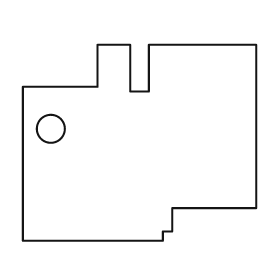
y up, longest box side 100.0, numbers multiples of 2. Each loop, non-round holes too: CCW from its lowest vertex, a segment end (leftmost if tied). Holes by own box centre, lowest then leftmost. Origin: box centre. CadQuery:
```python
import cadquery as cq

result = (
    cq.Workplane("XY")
    .moveTo(-50.0, -42.0)
    .lineTo(10.0, -42.0)
    .lineTo(10.0, -38.0)
    .lineTo(14.0, -38.0)
    .lineTo(14.0, -28.0)
    .lineTo(50.0, -28.0)
    .lineTo(50.0, 42.0)
    .lineTo(4.0, 42.0)
    .lineTo(4.0, 22.0)
    .lineTo(-4.0, 22.0)
    .lineTo(-4.0, 42.0)
    .lineTo(-18.0, 42.0)
    .lineTo(-18.0, 24.0)
    .lineTo(-50.0, 24.0)
    .close()
    .moveTo(-38.0, 6.0)
    .circle(6.0)
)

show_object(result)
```